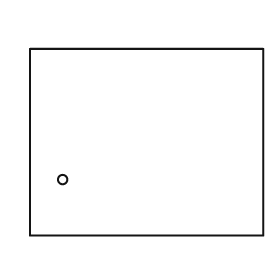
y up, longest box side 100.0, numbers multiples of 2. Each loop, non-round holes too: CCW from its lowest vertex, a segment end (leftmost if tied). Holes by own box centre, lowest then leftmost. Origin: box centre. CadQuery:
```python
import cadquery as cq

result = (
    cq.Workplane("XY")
    .moveTo(-50.0, -40.0)
    .lineTo(50.0, -40.0)
    .lineTo(50.0, 40.0)
    .lineTo(-50.0, 40.0)
    .close()
    .moveTo(-36.0, -16.0)
    .circle(2.0)
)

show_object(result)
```